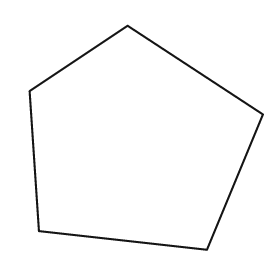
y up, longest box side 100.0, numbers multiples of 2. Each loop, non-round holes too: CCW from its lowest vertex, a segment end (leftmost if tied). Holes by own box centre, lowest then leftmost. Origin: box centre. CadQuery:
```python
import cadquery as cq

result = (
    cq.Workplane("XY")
    .moveTo(26.0, -48.0)
    .lineTo(50.0, 10.0)
    .lineTo(-8.0, 48.0)
    .lineTo(-50.0, 20.0)
    .lineTo(-46.0, -40.0)
    .close()
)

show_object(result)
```